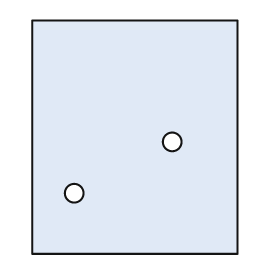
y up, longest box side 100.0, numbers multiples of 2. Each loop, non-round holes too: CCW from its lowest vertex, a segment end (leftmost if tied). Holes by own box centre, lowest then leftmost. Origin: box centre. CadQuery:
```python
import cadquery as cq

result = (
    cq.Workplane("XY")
    .moveTo(-44.0, -50.0)
    .lineTo(44.0, -50.0)
    .lineTo(44.0, 50.0)
    .lineTo(-44.0, 50.0)
    .close()
    .moveTo(-26.0, -24.0)
    .circle(4.0)
    .moveTo(16.0, -2.0)
    .circle(4.0)
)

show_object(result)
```